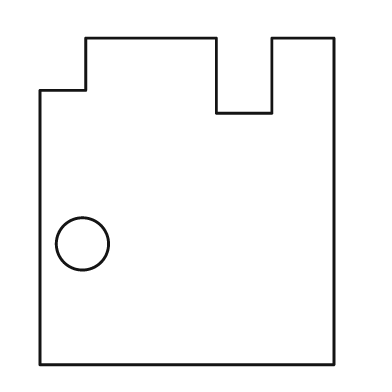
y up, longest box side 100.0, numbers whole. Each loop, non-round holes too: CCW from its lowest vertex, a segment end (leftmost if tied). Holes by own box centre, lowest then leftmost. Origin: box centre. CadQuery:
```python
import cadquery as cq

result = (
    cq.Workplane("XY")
    .moveTo(-45.0, -50.0)
    .lineTo(45.0, -50.0)
    .lineTo(45.0, 50.0)
    .lineTo(26.0, 50.0)
    .lineTo(26.0, 27.0)
    .lineTo(9.0, 27.0)
    .lineTo(9.0, 50.0)
    .lineTo(-31.0, 50.0)
    .lineTo(-31.0, 34.0)
    .lineTo(-45.0, 34.0)
    .close()
    .moveTo(-32.0, -13.0)
    .circle(8.0)
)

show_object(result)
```